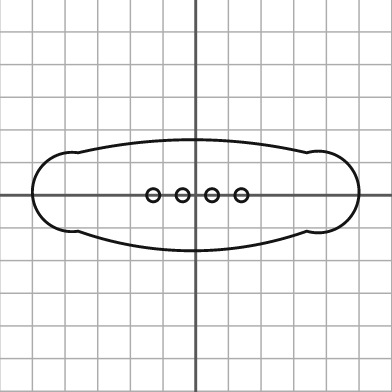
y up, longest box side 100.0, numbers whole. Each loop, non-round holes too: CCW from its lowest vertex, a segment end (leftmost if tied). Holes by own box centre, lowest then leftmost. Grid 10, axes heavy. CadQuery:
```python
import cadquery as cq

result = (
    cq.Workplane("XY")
    .moveTo(-36.0, -11.0)
    .threePointArc((-1.0, -17.0), (34.0, -11.0))
    .threePointArc((50.0, 1.0), (34.0, 13.0))
    .threePointArc((-1.0, 17.0), (-36.0, 13.0))
    .threePointArc((-50.0, 1.0), (-36.0, -11.0))
    .close()
    .moveTo(-13.0, 0.0)
    .circle(2.0)
    .moveTo(-4.0, 0.0)
    .circle(2.0)
    .moveTo(5.0, 0.0)
    .circle(2.0)
    .moveTo(14.0, 0.0)
    .circle(2.0)
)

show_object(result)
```